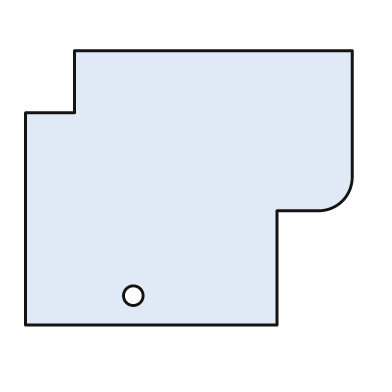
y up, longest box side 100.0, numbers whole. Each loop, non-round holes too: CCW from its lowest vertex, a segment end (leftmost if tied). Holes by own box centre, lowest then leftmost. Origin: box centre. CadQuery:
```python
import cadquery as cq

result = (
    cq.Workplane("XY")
    .moveTo(-50.0, -42.0)
    .lineTo(27.0, -42.0)
    .lineTo(27.0, -7.0)
    .lineTo(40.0, -7.0)
    .threePointArc((47.0, -4.0), (50.0, 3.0))
    .lineTo(50.0, 42.0)
    .lineTo(-35.0, 42.0)
    .lineTo(-35.0, 23.0)
    .lineTo(-50.0, 23.0)
    .close()
    .moveTo(-17.0, -33.0)
    .circle(3.0)
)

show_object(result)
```